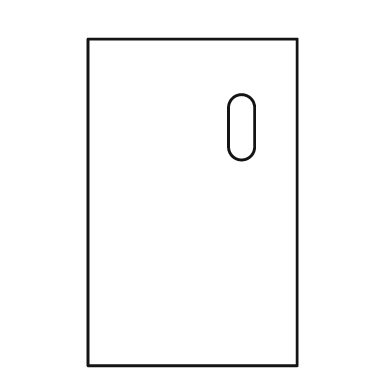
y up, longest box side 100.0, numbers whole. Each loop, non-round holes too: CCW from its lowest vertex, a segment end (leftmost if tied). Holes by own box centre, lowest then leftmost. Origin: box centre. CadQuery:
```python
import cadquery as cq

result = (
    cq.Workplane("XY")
    .moveTo(-32.0, -50.0)
    .lineTo(32.0, -50.0)
    .lineTo(32.0, 50.0)
    .lineTo(-32.0, 50.0)
    .close()
    .moveTo(11.0, 17.0)
    .threePointArc((15.0, 13.0), (19.0, 17.0))
    .lineTo(19.0, 29.0)
    .threePointArc((15.0, 33.0), (11.0, 29.0))
    .close()
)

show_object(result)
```